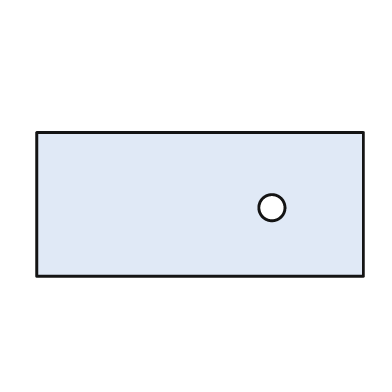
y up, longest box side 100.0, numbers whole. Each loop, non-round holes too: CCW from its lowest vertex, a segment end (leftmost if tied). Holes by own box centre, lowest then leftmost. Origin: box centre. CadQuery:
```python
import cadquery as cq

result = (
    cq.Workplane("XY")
    .moveTo(-50.0, -22.0)
    .lineTo(50.0, -22.0)
    .lineTo(50.0, 22.0)
    .lineTo(-50.0, 22.0)
    .close()
    .moveTo(22.0, -1.0)
    .circle(4.0)
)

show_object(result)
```